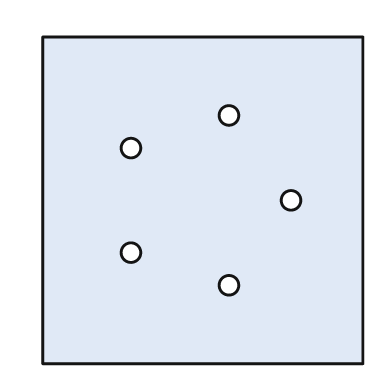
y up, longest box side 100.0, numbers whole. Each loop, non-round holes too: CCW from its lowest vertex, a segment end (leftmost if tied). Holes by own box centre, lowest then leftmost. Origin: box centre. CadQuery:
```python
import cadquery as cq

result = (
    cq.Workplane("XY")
    .moveTo(-49.0, -50.0)
    .lineTo(49.0, -50.0)
    .lineTo(49.0, 50.0)
    .lineTo(-49.0, 50.0)
    .close()
    .moveTo(8.0, -26.0)
    .circle(3.0)
    .moveTo(-22.0, -16.0)
    .circle(3.0)
    .moveTo(27.0, 0.0)
    .circle(3.0)
    .moveTo(-22.0, 16.0)
    .circle(3.0)
    .moveTo(8.0, 26.0)
    .circle(3.0)
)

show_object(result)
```